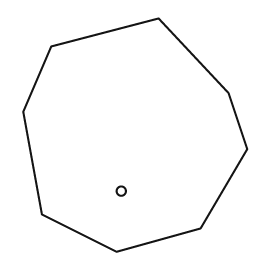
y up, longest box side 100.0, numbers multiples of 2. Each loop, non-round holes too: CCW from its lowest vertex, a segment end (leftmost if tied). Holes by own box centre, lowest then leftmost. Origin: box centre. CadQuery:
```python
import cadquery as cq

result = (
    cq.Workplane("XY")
    .moveTo(-8.0, -50.0)
    .lineTo(28.0, -40.0)
    .lineTo(48.0, -6.0)
    .lineTo(40.0, 18.0)
    .lineTo(10.0, 50.0)
    .lineTo(-36.0, 38.0)
    .lineTo(-48.0, 10.0)
    .lineTo(-40.0, -34.0)
    .close()
    .moveTo(-6.0, -24.0)
    .circle(2.0)
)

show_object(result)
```